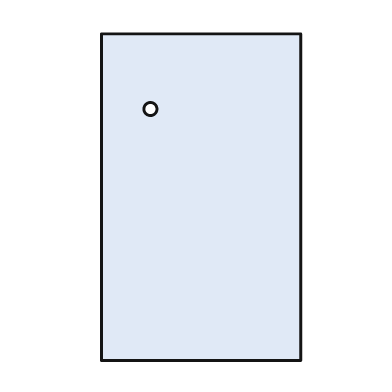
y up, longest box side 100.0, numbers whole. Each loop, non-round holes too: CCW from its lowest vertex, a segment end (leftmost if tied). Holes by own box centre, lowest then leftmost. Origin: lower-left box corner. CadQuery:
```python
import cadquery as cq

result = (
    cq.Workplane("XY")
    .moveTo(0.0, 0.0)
    .lineTo(61.0, 0.0)
    .lineTo(61.0, 100.0)
    .lineTo(0.0, 100.0)
    .close()
    .moveTo(15.0, 77.0)
    .circle(2.0)
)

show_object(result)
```